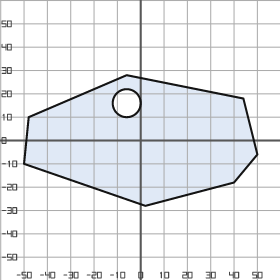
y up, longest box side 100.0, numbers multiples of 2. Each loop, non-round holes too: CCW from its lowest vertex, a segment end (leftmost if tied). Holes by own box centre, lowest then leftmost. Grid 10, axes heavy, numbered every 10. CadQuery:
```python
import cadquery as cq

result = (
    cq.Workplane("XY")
    .moveTo(2.0, -28.0)
    .lineTo(40.0, -18.0)
    .lineTo(50.0, -6.0)
    .lineTo(44.0, 18.0)
    .lineTo(-6.0, 28.0)
    .lineTo(-48.0, 10.0)
    .lineTo(-50.0, -10.0)
    .close()
    .moveTo(-6.0, 16.0)
    .circle(6.0)
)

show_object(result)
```